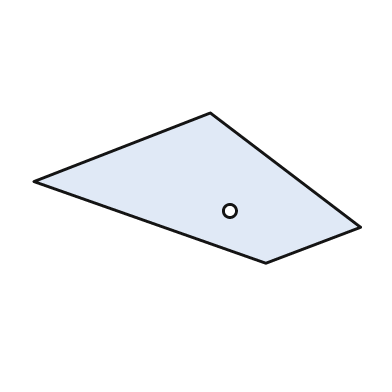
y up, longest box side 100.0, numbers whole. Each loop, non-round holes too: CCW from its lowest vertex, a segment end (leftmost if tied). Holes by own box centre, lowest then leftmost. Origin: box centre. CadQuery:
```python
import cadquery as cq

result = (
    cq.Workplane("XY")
    .moveTo(21.0, -23.0)
    .lineTo(50.0, -12.0)
    .lineTo(4.0, 23.0)
    .lineTo(-50.0, 2.0)
    .close()
    .moveTo(10.0, -7.0)
    .circle(2.0)
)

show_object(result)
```